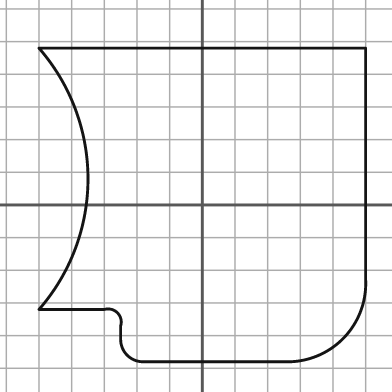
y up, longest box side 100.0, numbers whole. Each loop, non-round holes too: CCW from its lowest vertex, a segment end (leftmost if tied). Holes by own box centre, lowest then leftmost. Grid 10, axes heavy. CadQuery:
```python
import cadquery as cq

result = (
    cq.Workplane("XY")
    .moveTo(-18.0, -48.0)
    .lineTo(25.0, -48.0)
    .threePointArc((43.0, -41.0), (50.0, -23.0))
    .lineTo(50.0, 48.0)
    .lineTo(-50.0, 48.0)
    .threePointArc((-35.0, 8.0), (-50.0, -32.0))
    .lineTo(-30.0, -32.0)
    .threePointArc((-26.0, -33.0), (-25.0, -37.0))
    .lineTo(-25.0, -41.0)
    .threePointArc((-23.0, -46.0), (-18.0, -48.0))
    .close()
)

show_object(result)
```